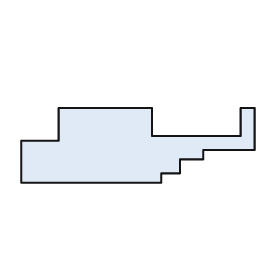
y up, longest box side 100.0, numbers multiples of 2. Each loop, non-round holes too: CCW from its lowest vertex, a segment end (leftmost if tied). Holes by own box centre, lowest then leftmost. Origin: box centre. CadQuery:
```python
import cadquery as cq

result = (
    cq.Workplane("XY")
    .moveTo(-50.0, -16.0)
    .lineTo(10.0, -16.0)
    .lineTo(10.0, -12.0)
    .lineTo(18.0, -12.0)
    .lineTo(18.0, -6.0)
    .lineTo(28.0, -6.0)
    .lineTo(28.0, -2.0)
    .lineTo(50.0, -2.0)
    .lineTo(50.0, 16.0)
    .lineTo(44.0, 16.0)
    .lineTo(44.0, 4.0)
    .lineTo(6.0, 4.0)
    .lineTo(6.0, 16.0)
    .lineTo(-34.0, 16.0)
    .lineTo(-34.0, 2.0)
    .lineTo(-50.0, 2.0)
    .close()
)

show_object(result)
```